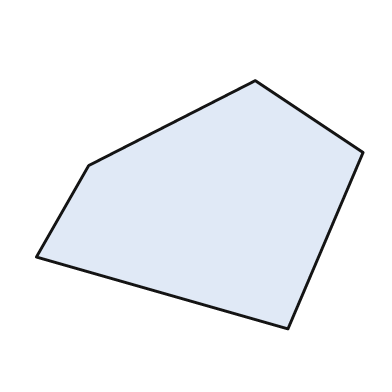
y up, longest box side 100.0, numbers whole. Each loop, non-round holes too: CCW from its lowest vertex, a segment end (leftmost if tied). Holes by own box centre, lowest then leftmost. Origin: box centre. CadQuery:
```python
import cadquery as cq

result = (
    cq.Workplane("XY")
    .moveTo(27.0, -38.0)
    .lineTo(50.0, 16.0)
    .lineTo(17.0, 38.0)
    .lineTo(-34.0, 12.0)
    .lineTo(-50.0, -16.0)
    .close()
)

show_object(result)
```